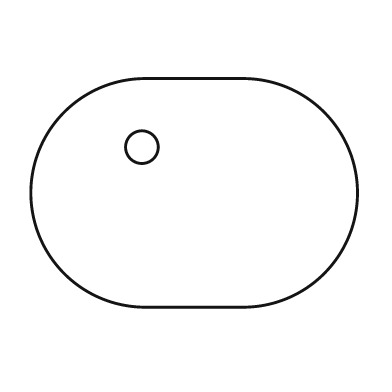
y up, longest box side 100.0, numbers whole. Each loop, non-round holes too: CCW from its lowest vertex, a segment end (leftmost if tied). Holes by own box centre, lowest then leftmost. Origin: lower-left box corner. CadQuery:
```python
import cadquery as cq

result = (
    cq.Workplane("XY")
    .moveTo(35.0, 0.0)
    .lineTo(65.0, 0.0)
    .threePointArc((100.0, 35.0), (65.0, 70.0))
    .lineTo(35.0, 70.0)
    .threePointArc((0.0, 35.0), (35.0, 0.0))
    .close()
    .moveTo(34.0, 49.0)
    .circle(5.0)
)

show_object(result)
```